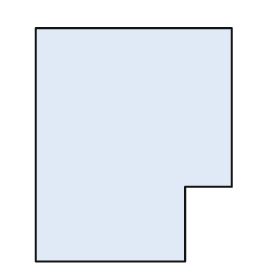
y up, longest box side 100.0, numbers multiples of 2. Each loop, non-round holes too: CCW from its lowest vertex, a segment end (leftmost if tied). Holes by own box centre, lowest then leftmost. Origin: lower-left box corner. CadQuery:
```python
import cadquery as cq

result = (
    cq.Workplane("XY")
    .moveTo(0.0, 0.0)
    .lineTo(64.0, 0.0)
    .lineTo(64.0, 32.0)
    .lineTo(84.0, 32.0)
    .lineTo(84.0, 100.0)
    .lineTo(0.0, 100.0)
    .close()
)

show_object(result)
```